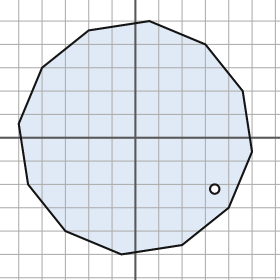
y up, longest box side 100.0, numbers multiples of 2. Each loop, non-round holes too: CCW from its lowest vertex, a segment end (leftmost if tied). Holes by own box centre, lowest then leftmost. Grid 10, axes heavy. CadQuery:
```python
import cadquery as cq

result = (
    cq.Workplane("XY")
    .moveTo(-6.0, -50.0)
    .lineTo(20.0, -46.0)
    .lineTo(40.0, -30.0)
    .lineTo(50.0, -6.0)
    .lineTo(46.0, 20.0)
    .lineTo(30.0, 40.0)
    .lineTo(6.0, 50.0)
    .lineTo(-20.0, 46.0)
    .lineTo(-40.0, 30.0)
    .lineTo(-50.0, 6.0)
    .lineTo(-46.0, -20.0)
    .lineTo(-30.0, -40.0)
    .close()
    .moveTo(34.0, -22.0)
    .circle(2.0)
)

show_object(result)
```